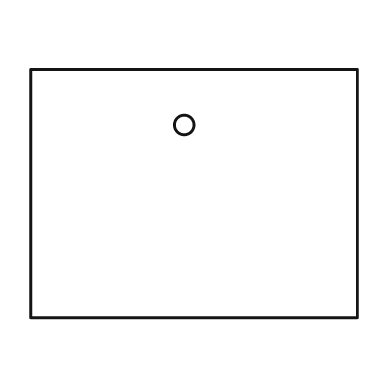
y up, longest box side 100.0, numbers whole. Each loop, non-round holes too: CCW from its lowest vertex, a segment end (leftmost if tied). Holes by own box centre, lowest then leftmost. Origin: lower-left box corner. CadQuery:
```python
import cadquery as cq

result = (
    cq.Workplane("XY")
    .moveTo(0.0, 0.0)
    .lineTo(100.0, 0.0)
    .lineTo(100.0, 76.0)
    .lineTo(0.0, 76.0)
    .close()
    .moveTo(47.0, 59.0)
    .circle(3.0)
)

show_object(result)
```